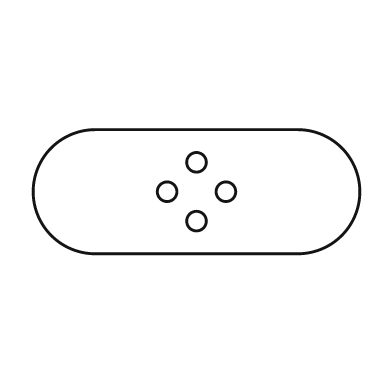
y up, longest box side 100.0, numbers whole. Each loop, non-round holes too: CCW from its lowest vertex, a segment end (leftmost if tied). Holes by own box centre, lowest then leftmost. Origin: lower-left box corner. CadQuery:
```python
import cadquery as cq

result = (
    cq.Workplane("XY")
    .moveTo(19.0, 0.0)
    .lineTo(81.0, 0.0)
    .threePointArc((100.0, 19.0), (81.0, 38.0))
    .lineTo(19.0, 38.0)
    .threePointArc((0.0, 19.0), (19.0, 0.0))
    .close()
    .moveTo(50.0, 10.0)
    .circle(3.0)
    .moveTo(41.0, 19.0)
    .circle(3.0)
    .moveTo(59.0, 19.0)
    .circle(3.0)
    .moveTo(50.0, 28.0)
    .circle(3.0)
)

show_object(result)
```